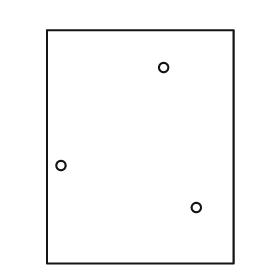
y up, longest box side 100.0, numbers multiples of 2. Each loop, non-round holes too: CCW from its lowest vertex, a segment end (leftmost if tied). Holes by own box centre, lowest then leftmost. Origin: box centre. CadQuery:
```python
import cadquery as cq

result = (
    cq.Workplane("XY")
    .moveTo(-40.0, -50.0)
    .lineTo(40.0, -50.0)
    .lineTo(40.0, 50.0)
    .lineTo(-40.0, 50.0)
    .close()
    .moveTo(24.0, -26.0)
    .circle(2.0)
    .moveTo(-34.0, -8.0)
    .circle(2.0)
    .moveTo(10.0, 34.0)
    .circle(2.0)
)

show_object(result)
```